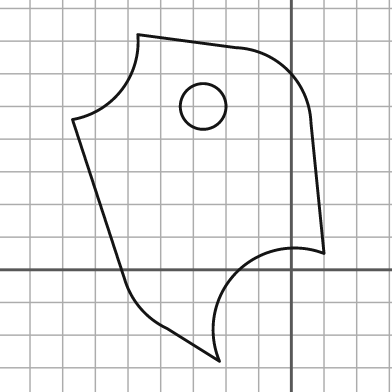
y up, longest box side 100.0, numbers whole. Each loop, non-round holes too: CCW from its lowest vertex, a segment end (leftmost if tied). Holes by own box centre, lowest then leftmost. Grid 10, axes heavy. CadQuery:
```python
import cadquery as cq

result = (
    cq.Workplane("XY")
    .moveTo(-22.0, -28.0)
    .threePointArc((-17.0, -1.0), (10.0, 5.0))
    .lineTo(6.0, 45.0)
    .threePointArc((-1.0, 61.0), (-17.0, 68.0))
    .lineTo(-47.0, 72.0)
    .threePointArc((-52.0, 55.0), (-67.0, 46.0))
    .lineTo(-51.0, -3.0)
    .threePointArc((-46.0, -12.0), (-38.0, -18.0))
    .close()
    .moveTo(-27.0, 50.0)
    .circle(7.0)
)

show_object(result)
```